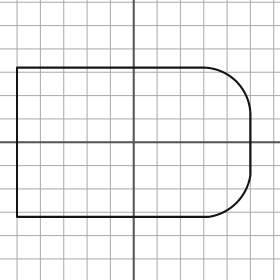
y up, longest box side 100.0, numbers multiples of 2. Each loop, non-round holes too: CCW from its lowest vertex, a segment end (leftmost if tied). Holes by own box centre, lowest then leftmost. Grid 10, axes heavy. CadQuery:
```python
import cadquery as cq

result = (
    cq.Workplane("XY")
    .moveTo(-50.0, -32.0)
    .lineTo(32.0, -32.0)
    .threePointArc((44.0, -26.0), (50.0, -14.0))
    .lineTo(50.0, 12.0)
    .threePointArc((44.0, 26.0), (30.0, 32.0))
    .lineTo(-50.0, 32.0)
    .close()
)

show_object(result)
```